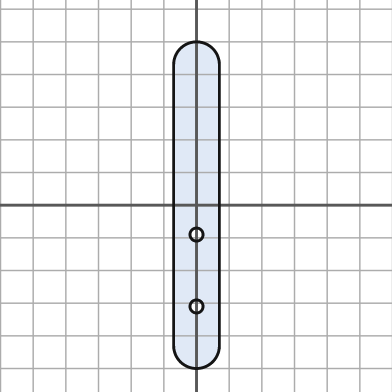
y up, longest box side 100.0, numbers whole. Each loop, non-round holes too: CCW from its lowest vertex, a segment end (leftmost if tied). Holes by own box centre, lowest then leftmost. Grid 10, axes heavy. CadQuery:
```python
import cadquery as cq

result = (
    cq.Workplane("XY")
    .moveTo(-7.0, -43.0)
    .threePointArc((0.0, -50.0), (7.0, -43.0))
    .lineTo(7.0, 43.0)
    .threePointArc((0.0, 50.0), (-7.0, 43.0))
    .close()
    .moveTo(0.0, -31.0)
    .circle(2.0)
    .moveTo(0.0, -9.0)
    .circle(2.0)
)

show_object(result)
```